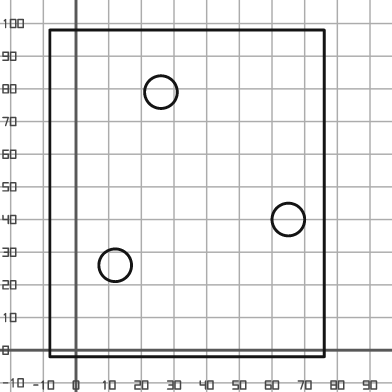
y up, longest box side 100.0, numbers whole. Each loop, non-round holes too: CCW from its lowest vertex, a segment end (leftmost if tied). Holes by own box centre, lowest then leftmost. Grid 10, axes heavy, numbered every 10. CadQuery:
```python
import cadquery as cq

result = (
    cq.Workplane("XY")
    .moveTo(-8.0, -2.0)
    .lineTo(76.0, -2.0)
    .lineTo(76.0, 98.0)
    .lineTo(-8.0, 98.0)
    .close()
    .moveTo(12.0, 26.0)
    .circle(5.0)
    .moveTo(65.0, 40.0)
    .circle(5.0)
    .moveTo(26.0, 79.0)
    .circle(5.0)
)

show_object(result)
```